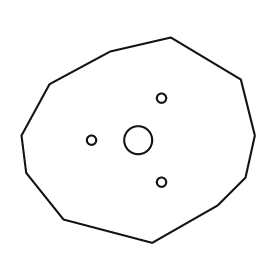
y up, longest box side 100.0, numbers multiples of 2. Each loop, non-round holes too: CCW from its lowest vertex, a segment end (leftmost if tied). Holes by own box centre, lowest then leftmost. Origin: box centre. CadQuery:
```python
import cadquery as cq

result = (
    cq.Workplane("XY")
    .moveTo(6.0, -44.0)
    .lineTo(34.0, -28.0)
    .lineTo(46.0, -16.0)
    .lineTo(50.0, 2.0)
    .lineTo(44.0, 26.0)
    .lineTo(14.0, 44.0)
    .lineTo(-12.0, 38.0)
    .lineTo(-38.0, 24.0)
    .lineTo(-50.0, 2.0)
    .lineTo(-48.0, -14.0)
    .lineTo(-32.0, -34.0)
    .close()
    .moveTo(10.0, -18.0)
    .circle(2.0)
    .moveTo(-20.0, 0.0)
    .circle(2.0)
    .moveTo(0.0, 0.0)
    .circle(6.0)
    .moveTo(10.0, 18.0)
    .circle(2.0)
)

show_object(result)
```